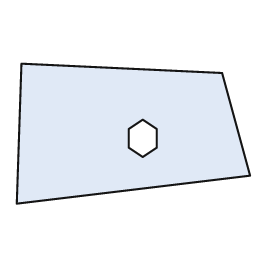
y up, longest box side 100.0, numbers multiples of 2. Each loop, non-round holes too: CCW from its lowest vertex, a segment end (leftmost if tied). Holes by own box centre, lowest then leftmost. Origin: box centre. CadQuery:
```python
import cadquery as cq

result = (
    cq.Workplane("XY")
    .moveTo(-50.0, -30.0)
    .lineTo(50.0, -18.0)
    .lineTo(38.0, 26.0)
    .lineTo(-48.0, 30.0)
    .close()
    .moveTo(4.0, -10.0)
    .lineTo(10.0, -6.0)
    .lineTo(10.0, 2.0)
    .lineTo(4.0, 6.0)
    .lineTo(-2.0, 2.0)
    .lineTo(-2.0, -6.0)
    .close()
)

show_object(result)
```